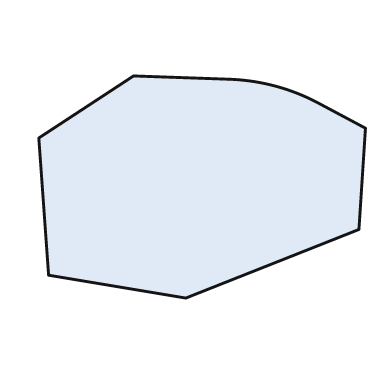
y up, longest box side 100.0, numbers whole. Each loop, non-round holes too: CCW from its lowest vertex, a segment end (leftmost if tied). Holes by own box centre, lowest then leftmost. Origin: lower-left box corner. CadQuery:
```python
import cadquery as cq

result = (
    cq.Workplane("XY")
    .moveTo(45.0, 0.0)
    .lineTo(98.0, 21.0)
    .lineTo(100.0, 52.0)
    .lineTo(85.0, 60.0)
    .threePointArc((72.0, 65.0), (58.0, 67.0))
    .lineTo(29.0, 68.0)
    .lineTo(0.0, 49.0)
    .lineTo(3.0, 7.0)
    .close()
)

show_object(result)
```